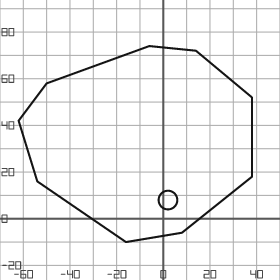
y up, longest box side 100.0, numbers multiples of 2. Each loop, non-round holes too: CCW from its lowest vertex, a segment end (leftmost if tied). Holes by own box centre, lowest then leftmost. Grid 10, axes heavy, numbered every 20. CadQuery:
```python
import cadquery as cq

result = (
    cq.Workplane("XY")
    .moveTo(-16.0, -10.0)
    .lineTo(8.0, -6.0)
    .lineTo(38.0, 18.0)
    .lineTo(38.0, 52.0)
    .lineTo(14.0, 72.0)
    .lineTo(-6.0, 74.0)
    .lineTo(-50.0, 58.0)
    .lineTo(-62.0, 42.0)
    .lineTo(-54.0, 16.0)
    .close()
    .moveTo(2.0, 8.0)
    .circle(4.0)
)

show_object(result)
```